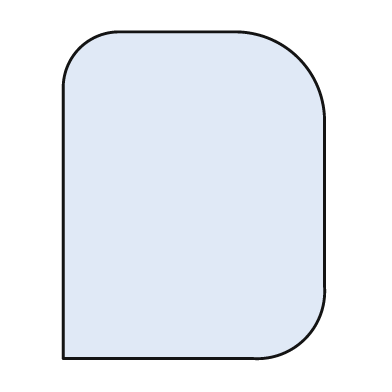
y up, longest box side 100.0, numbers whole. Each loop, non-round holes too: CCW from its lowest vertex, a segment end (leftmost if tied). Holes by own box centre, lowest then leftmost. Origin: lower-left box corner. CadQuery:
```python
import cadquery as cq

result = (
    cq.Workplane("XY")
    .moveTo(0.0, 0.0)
    .lineTo(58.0, 0.0)
    .threePointArc((74.0, 6.0), (80.0, 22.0))
    .lineTo(80.0, 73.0)
    .threePointArc((72.0, 92.0), (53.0, 100.0))
    .lineTo(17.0, 100.0)
    .threePointArc((5.0, 95.0), (0.0, 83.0))
    .close()
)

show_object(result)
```